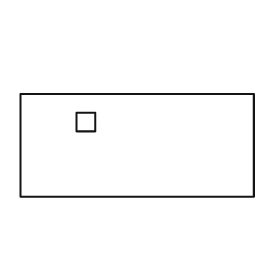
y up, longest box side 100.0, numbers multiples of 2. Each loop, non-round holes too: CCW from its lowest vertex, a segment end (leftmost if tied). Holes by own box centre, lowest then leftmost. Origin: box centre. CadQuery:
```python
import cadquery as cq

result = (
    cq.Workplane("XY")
    .moveTo(-50.0, -22.0)
    .lineTo(50.0, -22.0)
    .lineTo(50.0, 22.0)
    .lineTo(-50.0, 22.0)
    .close()
    .moveTo(-26.0, 6.0)
    .lineTo(-18.0, 6.0)
    .lineTo(-18.0, 14.0)
    .lineTo(-26.0, 14.0)
    .close()
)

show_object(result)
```